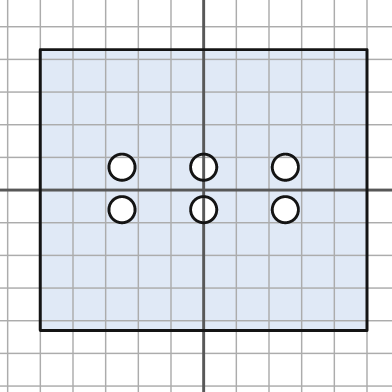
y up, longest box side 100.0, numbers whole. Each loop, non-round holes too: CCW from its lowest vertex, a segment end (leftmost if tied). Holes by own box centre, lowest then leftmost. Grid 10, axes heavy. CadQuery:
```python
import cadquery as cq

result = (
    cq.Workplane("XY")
    .moveTo(-50.0, -43.0)
    .lineTo(50.0, -43.0)
    .lineTo(50.0, 43.0)
    .lineTo(-50.0, 43.0)
    .close()
    .moveTo(-25.0, -6.0)
    .circle(4.0)
    .moveTo(0.0, -6.0)
    .circle(4.0)
    .moveTo(25.0, -6.0)
    .circle(4.0)
    .moveTo(-25.0, 7.0)
    .circle(4.0)
    .moveTo(0.0, 7.0)
    .circle(4.0)
    .moveTo(25.0, 7.0)
    .circle(4.0)
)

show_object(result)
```